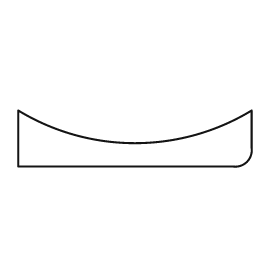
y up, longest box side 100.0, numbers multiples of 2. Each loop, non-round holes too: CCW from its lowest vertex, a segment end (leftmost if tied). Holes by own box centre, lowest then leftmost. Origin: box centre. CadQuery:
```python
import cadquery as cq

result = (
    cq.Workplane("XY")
    .moveTo(-50.0, -12.0)
    .lineTo(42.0, -12.0)
    .threePointArc((48.0, -10.0), (50.0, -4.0))
    .lineTo(50.0, 12.0)
    .threePointArc((0.0, -2.0), (-50.0, 12.0))
    .close()
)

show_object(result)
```